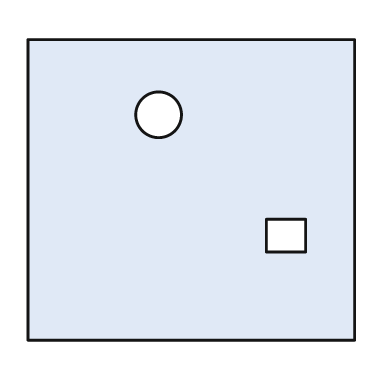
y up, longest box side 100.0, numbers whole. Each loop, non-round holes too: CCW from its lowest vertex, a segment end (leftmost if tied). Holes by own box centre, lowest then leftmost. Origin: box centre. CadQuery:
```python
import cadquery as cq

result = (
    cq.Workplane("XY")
    .moveTo(-50.0, -46.0)
    .lineTo(50.0, -46.0)
    .lineTo(50.0, 46.0)
    .lineTo(-50.0, 46.0)
    .close()
    .moveTo(23.0, -19.0)
    .lineTo(35.0, -19.0)
    .lineTo(35.0, -9.0)
    .lineTo(23.0, -9.0)
    .close()
    .moveTo(-10.0, 23.0)
    .circle(7.0)
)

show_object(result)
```